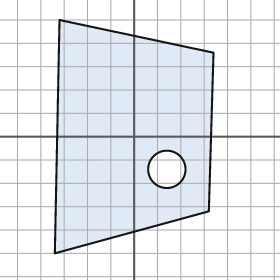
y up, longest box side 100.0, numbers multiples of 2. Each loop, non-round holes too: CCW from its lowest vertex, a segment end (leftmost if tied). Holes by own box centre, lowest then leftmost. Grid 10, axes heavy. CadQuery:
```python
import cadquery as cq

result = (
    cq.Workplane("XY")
    .moveTo(-34.0, -50.0)
    .lineTo(32.0, -32.0)
    .lineTo(34.0, 36.0)
    .lineTo(-32.0, 50.0)
    .close()
    .moveTo(14.0, -14.0)
    .circle(8.0)
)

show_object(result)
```